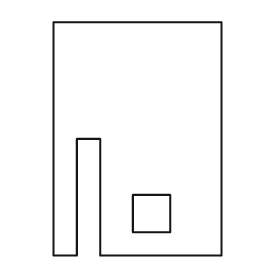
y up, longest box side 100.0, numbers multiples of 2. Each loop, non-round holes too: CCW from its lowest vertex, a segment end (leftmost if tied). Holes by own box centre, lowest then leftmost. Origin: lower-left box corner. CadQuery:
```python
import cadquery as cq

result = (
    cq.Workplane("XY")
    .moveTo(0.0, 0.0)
    .lineTo(10.0, 0.0)
    .lineTo(10.0, 50.0)
    .lineTo(20.0, 50.0)
    .lineTo(20.0, 0.0)
    .lineTo(72.0, 0.0)
    .lineTo(72.0, 100.0)
    .lineTo(0.0, 100.0)
    .close()
    .moveTo(34.0, 10.0)
    .lineTo(50.0, 10.0)
    .lineTo(50.0, 26.0)
    .lineTo(34.0, 26.0)
    .close()
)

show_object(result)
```